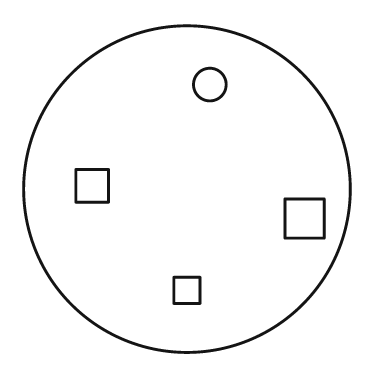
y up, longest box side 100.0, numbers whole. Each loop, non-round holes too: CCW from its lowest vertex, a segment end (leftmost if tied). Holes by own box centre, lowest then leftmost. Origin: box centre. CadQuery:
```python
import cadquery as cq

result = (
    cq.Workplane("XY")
    .moveTo(0.0, 0.0)
    .circle(50.0)
    .moveTo(-4.0, -35.0)
    .lineTo(4.0, -35.0)
    .lineTo(4.0, -27.0)
    .lineTo(-4.0, -27.0)
    .close()
    .moveTo(30.0, -15.0)
    .lineTo(42.0, -15.0)
    .lineTo(42.0, -3.0)
    .lineTo(30.0, -3.0)
    .close()
    .moveTo(-34.0, -4.0)
    .lineTo(-24.0, -4.0)
    .lineTo(-24.0, 6.0)
    .lineTo(-34.0, 6.0)
    .close()
    .moveTo(7.0, 32.0)
    .circle(5.0)
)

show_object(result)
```